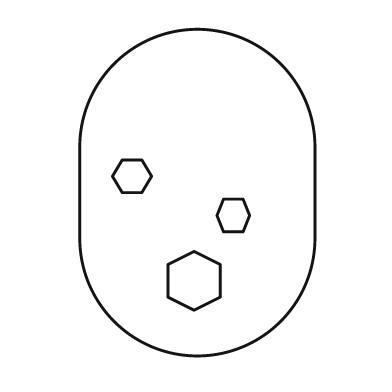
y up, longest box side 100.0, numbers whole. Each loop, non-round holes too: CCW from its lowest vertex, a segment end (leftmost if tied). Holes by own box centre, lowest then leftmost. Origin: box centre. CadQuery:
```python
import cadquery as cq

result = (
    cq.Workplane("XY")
    .moveTo(-36.0, -14.0)
    .threePointArc((0.0, -50.0), (36.0, -14.0))
    .lineTo(36.0, 14.0)
    .threePointArc((0.0, 50.0), (-36.0, 14.0))
    .close()
    .moveTo(-1.0, -36.0)
    .lineTo(7.0, -32.0)
    .lineTo(7.0, -22.0)
    .lineTo(-1.0, -18.0)
    .lineTo(-9.0, -22.0)
    .lineTo(-9.0, -32.0)
    .close()
    .moveTo(8.0, -12.0)
    .lineTo(14.0, -12.0)
    .lineTo(16.0, -7.0)
    .lineTo(14.0, -2.0)
    .lineTo(8.0, -2.0)
    .lineTo(6.0, -7.0)
    .close()
    .moveTo(-23.0, 0.0)
    .lineTo(-17.0, 0.0)
    .lineTo(-14.0, 5.0)
    .lineTo(-17.0, 10.0)
    .lineTo(-23.0, 10.0)
    .lineTo(-26.0, 5.0)
    .close()
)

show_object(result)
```